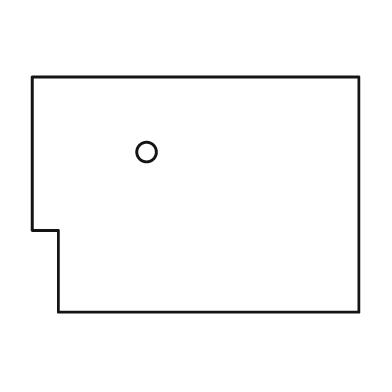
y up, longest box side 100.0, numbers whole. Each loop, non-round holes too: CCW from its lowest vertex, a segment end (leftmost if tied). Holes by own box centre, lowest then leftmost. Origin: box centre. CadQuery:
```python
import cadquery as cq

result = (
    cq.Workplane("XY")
    .moveTo(-42.0, -36.0)
    .lineTo(50.0, -36.0)
    .lineTo(50.0, 36.0)
    .lineTo(-50.0, 36.0)
    .lineTo(-50.0, -11.0)
    .lineTo(-42.0, -11.0)
    .close()
    .moveTo(-15.0, 13.0)
    .circle(3.0)
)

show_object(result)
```